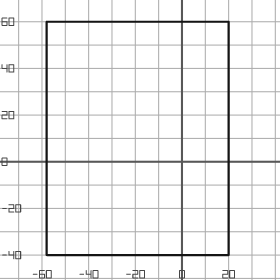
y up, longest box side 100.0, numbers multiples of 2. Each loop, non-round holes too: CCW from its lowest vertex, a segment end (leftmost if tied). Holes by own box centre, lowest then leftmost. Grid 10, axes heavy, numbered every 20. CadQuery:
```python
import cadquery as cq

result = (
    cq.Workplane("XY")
    .moveTo(-58.0, -40.0)
    .lineTo(20.0, -40.0)
    .lineTo(20.0, 60.0)
    .lineTo(-58.0, 60.0)
    .close()
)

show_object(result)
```